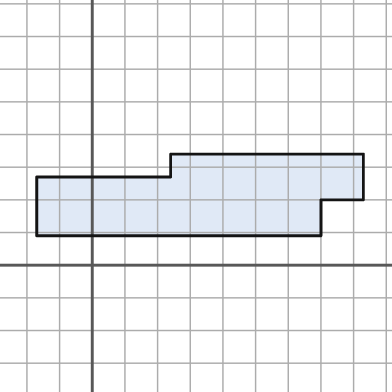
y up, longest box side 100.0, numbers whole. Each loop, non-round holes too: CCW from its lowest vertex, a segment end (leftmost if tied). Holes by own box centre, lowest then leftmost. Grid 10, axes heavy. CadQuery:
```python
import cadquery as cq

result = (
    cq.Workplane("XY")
    .moveTo(-17.0, 9.0)
    .lineTo(70.0, 9.0)
    .lineTo(70.0, 20.0)
    .lineTo(83.0, 20.0)
    .lineTo(83.0, 34.0)
    .lineTo(24.0, 34.0)
    .lineTo(24.0, 27.0)
    .lineTo(-17.0, 27.0)
    .close()
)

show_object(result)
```